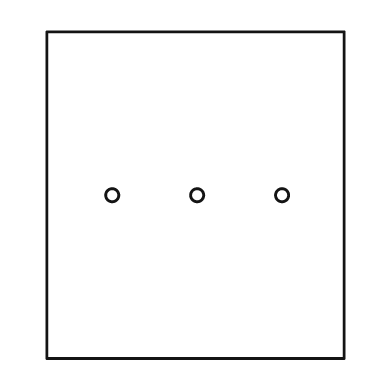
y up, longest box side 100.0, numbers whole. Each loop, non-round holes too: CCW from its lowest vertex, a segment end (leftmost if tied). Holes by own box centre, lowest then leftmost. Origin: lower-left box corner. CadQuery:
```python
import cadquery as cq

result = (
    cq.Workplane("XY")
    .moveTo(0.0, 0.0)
    .lineTo(91.0, 0.0)
    .lineTo(91.0, 100.0)
    .lineTo(0.0, 100.0)
    .close()
    .moveTo(20.0, 50.0)
    .circle(2.0)
    .moveTo(46.0, 50.0)
    .circle(2.0)
    .moveTo(72.0, 50.0)
    .circle(2.0)
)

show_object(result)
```